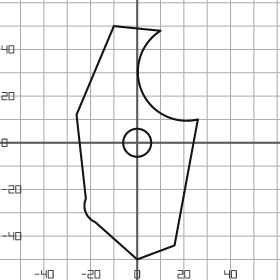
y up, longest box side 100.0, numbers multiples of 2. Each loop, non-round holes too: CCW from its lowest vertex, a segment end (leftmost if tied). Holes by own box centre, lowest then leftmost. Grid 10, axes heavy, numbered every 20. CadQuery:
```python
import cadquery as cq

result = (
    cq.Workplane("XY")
    .moveTo(0.0, -50.0)
    .lineTo(16.0, -44.0)
    .lineTo(26.0, 10.0)
    .threePointArc((2.0, 22.0), (10.0, 48.0))
    .lineTo(-10.0, 50.0)
    .lineTo(-26.0, 12.0)
    .lineTo(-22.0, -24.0)
    .threePointArc((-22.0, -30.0), (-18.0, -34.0))
    .close()
    .moveTo(0.0, 0.0)
    .circle(6.0)
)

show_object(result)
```